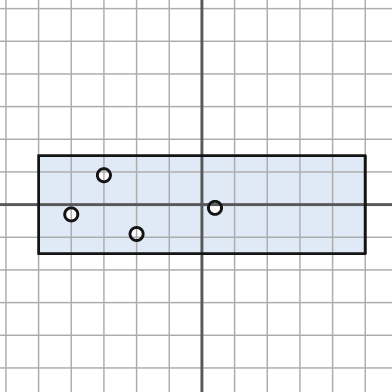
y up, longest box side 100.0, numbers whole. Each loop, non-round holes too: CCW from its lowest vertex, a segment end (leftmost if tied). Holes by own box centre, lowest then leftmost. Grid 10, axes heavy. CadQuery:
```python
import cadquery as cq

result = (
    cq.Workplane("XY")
    .moveTo(-50.0, -15.0)
    .lineTo(50.0, -15.0)
    .lineTo(50.0, 15.0)
    .lineTo(-50.0, 15.0)
    .close()
    .moveTo(-20.0, -9.0)
    .circle(2.0)
    .moveTo(-40.0, -3.0)
    .circle(2.0)
    .moveTo(4.0, -1.0)
    .circle(2.0)
    .moveTo(-30.0, 9.0)
    .circle(2.0)
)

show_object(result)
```